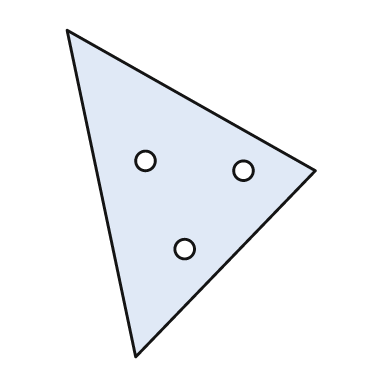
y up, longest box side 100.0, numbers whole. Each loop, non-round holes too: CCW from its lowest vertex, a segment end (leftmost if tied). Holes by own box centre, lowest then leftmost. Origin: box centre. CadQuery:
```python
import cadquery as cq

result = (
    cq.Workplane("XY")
    .moveTo(-17.0, -50.0)
    .lineTo(38.0, 7.0)
    .lineTo(-38.0, 50.0)
    .close()
    .moveTo(-2.0, -17.0)
    .circle(3.0)
    .moveTo(16.0, 7.0)
    .circle(3.0)
    .moveTo(-14.0, 10.0)
    .circle(3.0)
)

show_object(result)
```